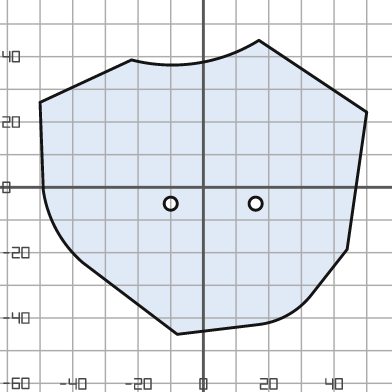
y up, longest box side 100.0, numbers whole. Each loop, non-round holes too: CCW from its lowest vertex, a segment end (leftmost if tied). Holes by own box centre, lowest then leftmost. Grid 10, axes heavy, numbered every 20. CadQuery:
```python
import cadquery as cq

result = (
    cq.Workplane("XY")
    .moveTo(-8.0, -45.0)
    .lineTo(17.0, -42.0)
    .threePointArc((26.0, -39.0), (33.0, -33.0))
    .lineTo(44.0, -19.0)
    .lineTo(50.0, 23.0)
    .lineTo(17.0, 45.0)
    .threePointArc((-2.0, 38.0), (-22.0, 39.0))
    .lineTo(-50.0, 26.0)
    .lineTo(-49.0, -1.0)
    .threePointArc((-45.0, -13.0), (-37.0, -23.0))
    .close()
    .moveTo(-10.0, -5.0)
    .circle(2.0)
    .moveTo(16.0, -5.0)
    .circle(2.0)
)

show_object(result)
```